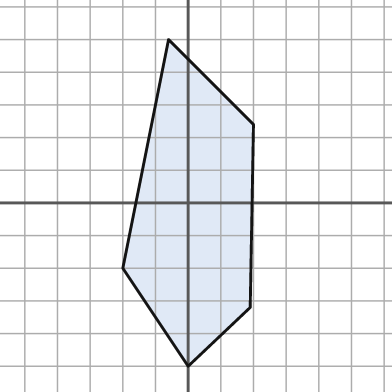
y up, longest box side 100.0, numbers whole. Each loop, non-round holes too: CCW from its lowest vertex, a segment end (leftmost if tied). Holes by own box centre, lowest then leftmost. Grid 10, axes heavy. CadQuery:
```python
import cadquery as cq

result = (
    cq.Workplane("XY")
    .moveTo(0.0, -50.0)
    .lineTo(19.0, -32.0)
    .lineTo(20.0, 24.0)
    .lineTo(-6.0, 50.0)
    .lineTo(-20.0, -20.0)
    .close()
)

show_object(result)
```